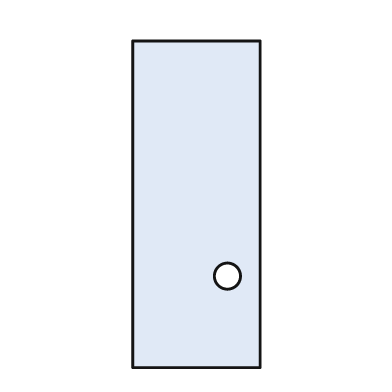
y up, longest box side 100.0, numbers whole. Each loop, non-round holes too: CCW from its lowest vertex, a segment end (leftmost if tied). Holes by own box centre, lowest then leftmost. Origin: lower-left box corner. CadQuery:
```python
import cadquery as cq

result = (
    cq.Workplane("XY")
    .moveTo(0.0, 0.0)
    .lineTo(39.0, 0.0)
    .lineTo(39.0, 100.0)
    .lineTo(0.0, 100.0)
    .close()
    .moveTo(29.0, 28.0)
    .circle(4.0)
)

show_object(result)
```